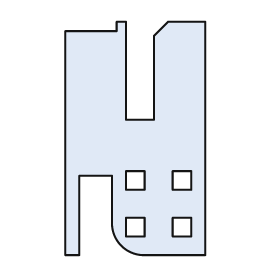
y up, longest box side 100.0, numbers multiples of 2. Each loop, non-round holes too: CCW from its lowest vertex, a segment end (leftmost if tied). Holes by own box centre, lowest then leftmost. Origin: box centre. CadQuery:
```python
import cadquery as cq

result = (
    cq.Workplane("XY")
    .moveTo(-30.0, -50.0)
    .lineTo(-24.0, -50.0)
    .lineTo(-24.0, -16.0)
    .lineTo(-10.0, -16.0)
    .lineTo(-10.0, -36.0)
    .threePointArc((-6.0, -46.0), (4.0, -50.0))
    .lineTo(30.0, -50.0)
    .lineTo(30.0, 50.0)
    .lineTo(14.0, 50.0)
    .lineTo(8.0, 44.0)
    .lineTo(8.0, 8.0)
    .lineTo(-4.0, 8.0)
    .lineTo(-4.0, 50.0)
    .lineTo(-8.0, 50.0)
    .lineTo(-8.0, 46.0)
    .lineTo(-30.0, 46.0)
    .close()
    .moveTo(-4.0, -42.0)
    .lineTo(4.0, -42.0)
    .lineTo(4.0, -34.0)
    .lineTo(-4.0, -34.0)
    .close()
    .moveTo(16.0, -42.0)
    .lineTo(24.0, -42.0)
    .lineTo(24.0, -34.0)
    .lineTo(16.0, -34.0)
    .close()
    .moveTo(-4.0, -22.0)
    .lineTo(4.0, -22.0)
    .lineTo(4.0, -14.0)
    .lineTo(-4.0, -14.0)
    .close()
    .moveTo(16.0, -22.0)
    .lineTo(24.0, -22.0)
    .lineTo(24.0, -14.0)
    .lineTo(16.0, -14.0)
    .close()
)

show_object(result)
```